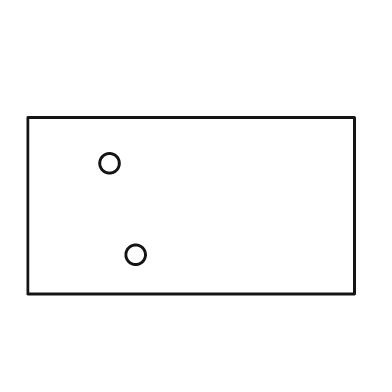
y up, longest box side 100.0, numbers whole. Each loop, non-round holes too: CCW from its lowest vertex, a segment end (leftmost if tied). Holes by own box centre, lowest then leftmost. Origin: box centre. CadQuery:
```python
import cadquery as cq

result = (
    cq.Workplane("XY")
    .moveTo(-50.0, -27.0)
    .lineTo(50.0, -27.0)
    .lineTo(50.0, 27.0)
    .lineTo(-50.0, 27.0)
    .close()
    .moveTo(-17.0, -15.0)
    .circle(3.0)
    .moveTo(-25.0, 13.0)
    .circle(3.0)
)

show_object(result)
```